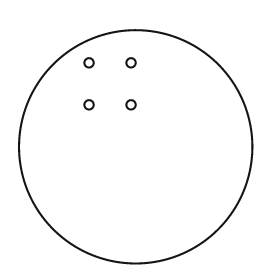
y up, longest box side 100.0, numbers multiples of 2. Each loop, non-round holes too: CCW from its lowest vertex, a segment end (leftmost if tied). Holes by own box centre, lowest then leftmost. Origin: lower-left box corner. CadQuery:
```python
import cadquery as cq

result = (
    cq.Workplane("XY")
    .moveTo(50.0, 50.0)
    .circle(50.0)
    .moveTo(30.0, 68.0)
    .circle(2.0)
    .moveTo(48.0, 68.0)
    .circle(2.0)
    .moveTo(30.0, 86.0)
    .circle(2.0)
    .moveTo(48.0, 86.0)
    .circle(2.0)
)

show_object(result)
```